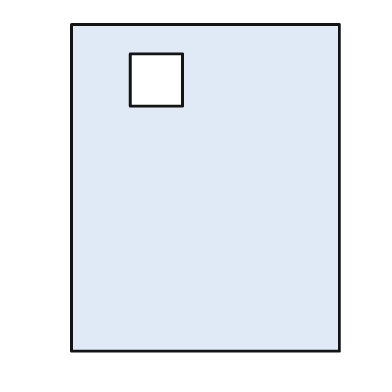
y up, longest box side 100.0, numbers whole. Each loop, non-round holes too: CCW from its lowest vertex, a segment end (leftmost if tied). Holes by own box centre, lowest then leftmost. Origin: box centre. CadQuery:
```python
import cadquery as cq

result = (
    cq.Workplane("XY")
    .moveTo(-41.0, -50.0)
    .lineTo(41.0, -50.0)
    .lineTo(41.0, 50.0)
    .lineTo(-41.0, 50.0)
    .close()
    .moveTo(-23.0, 25.0)
    .lineTo(-7.0, 25.0)
    .lineTo(-7.0, 41.0)
    .lineTo(-23.0, 41.0)
    .close()
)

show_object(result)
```